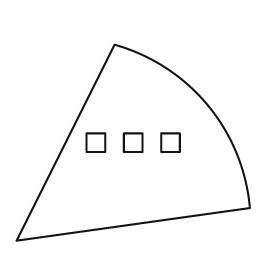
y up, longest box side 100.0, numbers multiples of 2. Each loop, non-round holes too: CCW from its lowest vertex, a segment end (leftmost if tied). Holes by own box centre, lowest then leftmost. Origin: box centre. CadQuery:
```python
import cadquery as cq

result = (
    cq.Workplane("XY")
    .moveTo(-50.0, -42.0)
    .lineTo(50.0, -28.0)
    .threePointArc((32.0, 16.0), (-8.0, 42.0))
    .close()
    .moveTo(-20.0, -4.0)
    .lineTo(-12.0, -4.0)
    .lineTo(-12.0, 4.0)
    .lineTo(-20.0, 4.0)
    .close()
    .moveTo(-4.0, -4.0)
    .lineTo(4.0, -4.0)
    .lineTo(4.0, 4.0)
    .lineTo(-4.0, 4.0)
    .close()
    .moveTo(12.0, -4.0)
    .lineTo(20.0, -4.0)
    .lineTo(20.0, 4.0)
    .lineTo(12.0, 4.0)
    .close()
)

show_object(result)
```